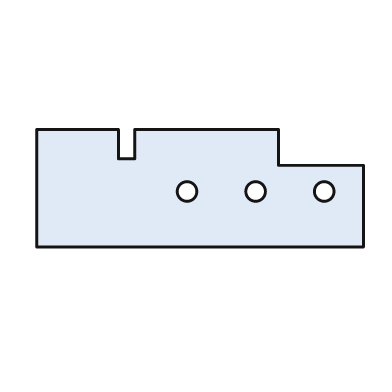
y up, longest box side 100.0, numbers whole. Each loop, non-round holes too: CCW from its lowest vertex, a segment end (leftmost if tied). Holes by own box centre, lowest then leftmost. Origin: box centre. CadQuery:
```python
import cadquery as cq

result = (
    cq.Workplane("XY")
    .moveTo(-50.0, -18.0)
    .lineTo(50.0, -18.0)
    .lineTo(50.0, 7.0)
    .lineTo(24.0, 7.0)
    .lineTo(24.0, 18.0)
    .lineTo(-20.0, 18.0)
    .lineTo(-20.0, 9.0)
    .lineTo(-25.0, 9.0)
    .lineTo(-25.0, 18.0)
    .lineTo(-50.0, 18.0)
    .close()
    .moveTo(-4.0, -1.0)
    .circle(3.0)
    .moveTo(17.0, -1.0)
    .circle(3.0)
    .moveTo(38.0, -1.0)
    .circle(3.0)
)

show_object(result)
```